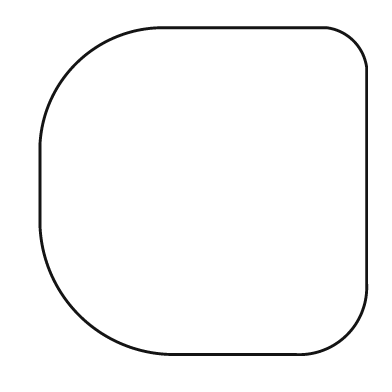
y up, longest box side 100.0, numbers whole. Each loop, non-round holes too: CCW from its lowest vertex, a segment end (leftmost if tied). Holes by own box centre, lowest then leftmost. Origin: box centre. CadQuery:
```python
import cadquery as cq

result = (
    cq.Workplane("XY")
    .moveTo(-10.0, -50.0)
    .lineTo(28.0, -50.0)
    .threePointArc((44.0, -44.0), (50.0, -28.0))
    .lineTo(50.0, 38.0)
    .threePointArc((46.0, 46.0), (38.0, 50.0))
    .lineTo(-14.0, 50.0)
    .threePointArc((-39.0, 39.0), (-50.0, 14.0))
    .lineTo(-50.0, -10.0)
    .threePointArc((-38.0, -38.0), (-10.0, -50.0))
    .close()
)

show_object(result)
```